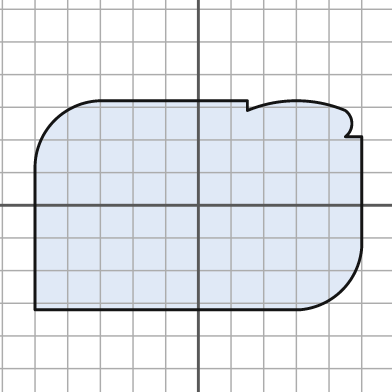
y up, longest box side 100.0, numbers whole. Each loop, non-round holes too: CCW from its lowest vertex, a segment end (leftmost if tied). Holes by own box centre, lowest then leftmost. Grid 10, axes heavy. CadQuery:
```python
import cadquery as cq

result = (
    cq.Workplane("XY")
    .moveTo(-50.0, -32.0)
    .lineTo(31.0, -32.0)
    .threePointArc((44.0, -26.0), (50.0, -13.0))
    .lineTo(50.0, 21.0)
    .lineTo(45.0, 21.0)
    .threePointArc((47.0, 25.0), (45.0, 29.0))
    .threePointArc((30.0, 32.0), (15.0, 29.0))
    .lineTo(15.0, 32.0)
    .lineTo(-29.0, 32.0)
    .threePointArc((-44.0, 26.0), (-50.0, 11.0))
    .close()
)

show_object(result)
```